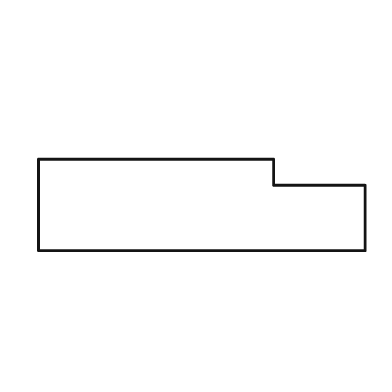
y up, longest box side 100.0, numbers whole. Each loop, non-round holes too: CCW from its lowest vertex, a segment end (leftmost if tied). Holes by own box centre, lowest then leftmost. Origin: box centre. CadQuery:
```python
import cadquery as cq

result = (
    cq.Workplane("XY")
    .moveTo(-50.0, -14.0)
    .lineTo(50.0, -14.0)
    .lineTo(50.0, 6.0)
    .lineTo(22.0, 6.0)
    .lineTo(22.0, 14.0)
    .lineTo(-50.0, 14.0)
    .close()
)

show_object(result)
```